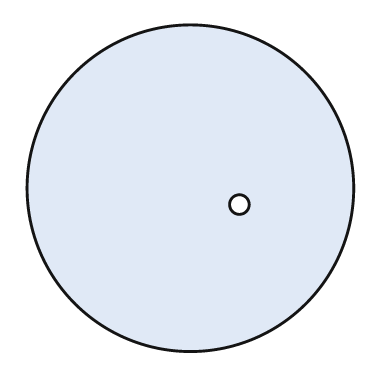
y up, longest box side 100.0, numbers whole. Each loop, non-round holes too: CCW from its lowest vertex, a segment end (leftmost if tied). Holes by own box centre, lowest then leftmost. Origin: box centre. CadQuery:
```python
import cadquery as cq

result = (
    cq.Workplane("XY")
    .moveTo(0.0, 0.0)
    .circle(50.0)
    .moveTo(15.0, -5.0)
    .circle(3.0)
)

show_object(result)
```